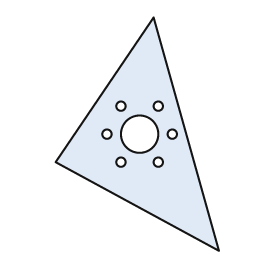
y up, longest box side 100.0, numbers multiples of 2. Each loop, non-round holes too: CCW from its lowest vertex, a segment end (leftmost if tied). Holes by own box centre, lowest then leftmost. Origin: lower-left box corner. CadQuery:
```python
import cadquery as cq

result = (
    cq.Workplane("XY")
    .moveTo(70.0, 0.0)
    .lineTo(42.0, 100.0)
    .lineTo(0.0, 38.0)
    .close()
    .moveTo(28.0, 38.0)
    .circle(2.0)
    .moveTo(44.0, 38.0)
    .circle(2.0)
    .moveTo(22.0, 50.0)
    .circle(2.0)
    .moveTo(36.0, 50.0)
    .circle(8.0)
    .moveTo(50.0, 50.0)
    .circle(2.0)
    .moveTo(28.0, 62.0)
    .circle(2.0)
    .moveTo(44.0, 62.0)
    .circle(2.0)
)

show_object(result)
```